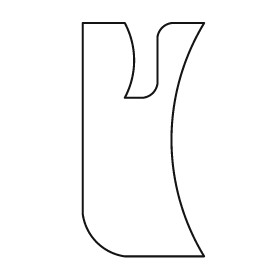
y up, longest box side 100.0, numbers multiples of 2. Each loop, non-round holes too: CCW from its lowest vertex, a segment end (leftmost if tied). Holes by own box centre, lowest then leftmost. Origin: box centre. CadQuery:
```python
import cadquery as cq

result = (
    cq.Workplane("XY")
    .moveTo(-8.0, -50.0)
    .lineTo(26.0, -50.0)
    .threePointArc((12.0, 0.0), (26.0, 50.0))
    .lineTo(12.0, 50.0)
    .threePointArc((8.0, 48.0), (6.0, 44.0))
    .lineTo(6.0, 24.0)
    .threePointArc((4.0, 20.0), (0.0, 18.0))
    .lineTo(-8.0, 18.0)
    .threePointArc((-4.0, 34.0), (-8.0, 50.0))
    .lineTo(-26.0, 50.0)
    .lineTo(-26.0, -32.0)
    .threePointArc((-20.0, -44.0), (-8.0, -50.0))
    .close()
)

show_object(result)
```